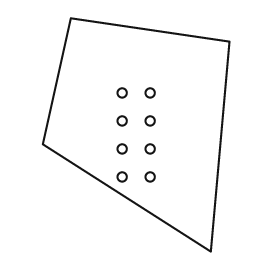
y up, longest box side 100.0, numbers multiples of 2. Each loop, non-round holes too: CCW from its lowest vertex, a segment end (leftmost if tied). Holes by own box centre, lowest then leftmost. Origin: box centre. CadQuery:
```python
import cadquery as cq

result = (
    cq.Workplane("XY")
    .moveTo(32.0, -50.0)
    .lineTo(40.0, 40.0)
    .lineTo(-28.0, 50.0)
    .lineTo(-40.0, -4.0)
    .close()
    .moveTo(-6.0, -18.0)
    .circle(2.0)
    .moveTo(6.0, -18.0)
    .circle(2.0)
    .moveTo(-6.0, -6.0)
    .circle(2.0)
    .moveTo(6.0, -6.0)
    .circle(2.0)
    .moveTo(-6.0, 6.0)
    .circle(2.0)
    .moveTo(6.0, 6.0)
    .circle(2.0)
    .moveTo(-6.0, 18.0)
    .circle(2.0)
    .moveTo(6.0, 18.0)
    .circle(2.0)
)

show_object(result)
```